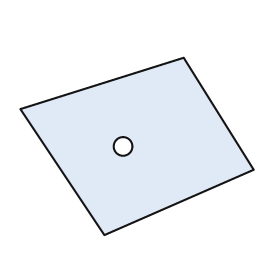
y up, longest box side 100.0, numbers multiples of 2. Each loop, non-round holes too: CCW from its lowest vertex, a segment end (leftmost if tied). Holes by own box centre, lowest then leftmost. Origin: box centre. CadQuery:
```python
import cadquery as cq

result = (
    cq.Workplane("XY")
    .moveTo(-14.0, -38.0)
    .lineTo(50.0, -10.0)
    .lineTo(20.0, 38.0)
    .lineTo(-50.0, 16.0)
    .close()
    .moveTo(-6.0, 0.0)
    .circle(4.0)
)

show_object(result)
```